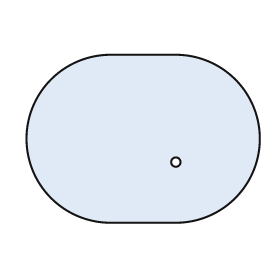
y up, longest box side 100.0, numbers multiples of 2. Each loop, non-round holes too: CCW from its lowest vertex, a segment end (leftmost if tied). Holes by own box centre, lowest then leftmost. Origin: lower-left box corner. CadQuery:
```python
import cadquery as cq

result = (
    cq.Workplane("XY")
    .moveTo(36.0, 0.0)
    .lineTo(64.0, 0.0)
    .threePointArc((100.0, 36.0), (64.0, 72.0))
    .lineTo(36.0, 72.0)
    .threePointArc((0.0, 36.0), (36.0, 0.0))
    .close()
    .moveTo(64.0, 26.0)
    .circle(2.0)
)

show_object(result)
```